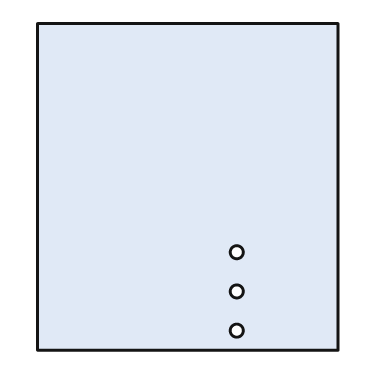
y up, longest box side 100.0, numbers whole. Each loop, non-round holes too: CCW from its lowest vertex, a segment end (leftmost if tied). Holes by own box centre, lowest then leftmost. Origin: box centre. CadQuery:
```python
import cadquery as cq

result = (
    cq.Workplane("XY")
    .moveTo(-46.0, -50.0)
    .lineTo(46.0, -50.0)
    .lineTo(46.0, 50.0)
    .lineTo(-46.0, 50.0)
    .close()
    .moveTo(15.0, -44.0)
    .circle(2.0)
    .moveTo(15.0, -32.0)
    .circle(2.0)
    .moveTo(15.0, -20.0)
    .circle(2.0)
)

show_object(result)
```